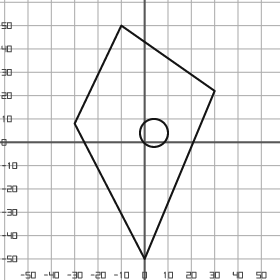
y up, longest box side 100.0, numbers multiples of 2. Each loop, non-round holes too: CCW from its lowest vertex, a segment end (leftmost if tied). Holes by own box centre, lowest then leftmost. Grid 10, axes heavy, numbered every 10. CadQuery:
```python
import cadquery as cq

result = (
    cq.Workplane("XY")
    .moveTo(0.0, -50.0)
    .lineTo(30.0, 22.0)
    .lineTo(-10.0, 50.0)
    .lineTo(-30.0, 8.0)
    .close()
    .moveTo(4.0, 4.0)
    .circle(6.0)
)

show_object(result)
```